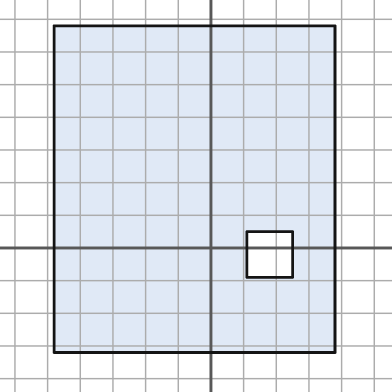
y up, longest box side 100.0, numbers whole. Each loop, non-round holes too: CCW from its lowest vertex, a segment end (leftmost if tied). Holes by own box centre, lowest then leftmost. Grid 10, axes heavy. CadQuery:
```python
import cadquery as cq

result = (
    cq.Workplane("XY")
    .moveTo(-48.0, -32.0)
    .lineTo(38.0, -32.0)
    .lineTo(38.0, 68.0)
    .lineTo(-48.0, 68.0)
    .close()
    .moveTo(11.0, -9.0)
    .lineTo(25.0, -9.0)
    .lineTo(25.0, 5.0)
    .lineTo(11.0, 5.0)
    .close()
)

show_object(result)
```